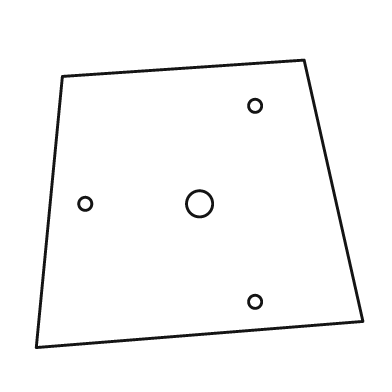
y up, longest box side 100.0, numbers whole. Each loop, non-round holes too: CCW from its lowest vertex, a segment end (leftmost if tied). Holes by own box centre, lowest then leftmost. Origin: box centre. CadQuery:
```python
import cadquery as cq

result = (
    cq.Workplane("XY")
    .moveTo(-50.0, -44.0)
    .lineTo(50.0, -36.0)
    .lineTo(32.0, 44.0)
    .lineTo(-42.0, 39.0)
    .close()
    .moveTo(17.0, -30.0)
    .circle(2.0)
    .moveTo(-35.0, 0.0)
    .circle(2.0)
    .moveTo(0.0, 0.0)
    .circle(4.0)
    .moveTo(17.0, 30.0)
    .circle(2.0)
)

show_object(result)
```